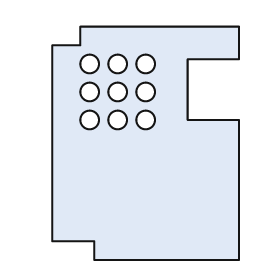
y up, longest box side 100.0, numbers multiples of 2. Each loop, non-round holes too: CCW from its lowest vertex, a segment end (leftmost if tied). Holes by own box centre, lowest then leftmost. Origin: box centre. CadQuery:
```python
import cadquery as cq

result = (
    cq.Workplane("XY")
    .moveTo(-22.0, -50.0)
    .lineTo(40.0, -50.0)
    .lineTo(40.0, 10.0)
    .lineTo(18.0, 10.0)
    .lineTo(18.0, 36.0)
    .lineTo(40.0, 36.0)
    .lineTo(40.0, 50.0)
    .lineTo(-28.0, 50.0)
    .lineTo(-28.0, 42.0)
    .lineTo(-40.0, 42.0)
    .lineTo(-40.0, -42.0)
    .lineTo(-22.0, -42.0)
    .close()
    .moveTo(-24.0, 10.0)
    .circle(4.0)
    .moveTo(-12.0, 10.0)
    .circle(4.0)
    .moveTo(0.0, 10.0)
    .circle(4.0)
    .moveTo(-24.0, 22.0)
    .circle(4.0)
    .moveTo(-12.0, 22.0)
    .circle(4.0)
    .moveTo(0.0, 22.0)
    .circle(4.0)
    .moveTo(-24.0, 34.0)
    .circle(4.0)
    .moveTo(-12.0, 34.0)
    .circle(4.0)
    .moveTo(0.0, 34.0)
    .circle(4.0)
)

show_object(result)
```